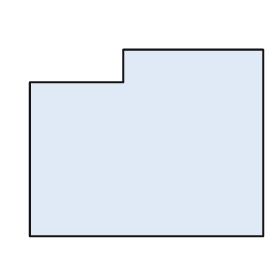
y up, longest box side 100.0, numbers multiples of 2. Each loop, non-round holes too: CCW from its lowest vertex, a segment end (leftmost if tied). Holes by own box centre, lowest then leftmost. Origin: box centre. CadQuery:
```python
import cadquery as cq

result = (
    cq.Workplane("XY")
    .moveTo(-50.0, -40.0)
    .lineTo(50.0, -40.0)
    .lineTo(50.0, 40.0)
    .lineTo(-10.0, 40.0)
    .lineTo(-10.0, 26.0)
    .lineTo(-50.0, 26.0)
    .close()
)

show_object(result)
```